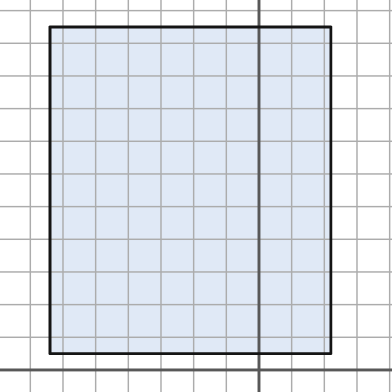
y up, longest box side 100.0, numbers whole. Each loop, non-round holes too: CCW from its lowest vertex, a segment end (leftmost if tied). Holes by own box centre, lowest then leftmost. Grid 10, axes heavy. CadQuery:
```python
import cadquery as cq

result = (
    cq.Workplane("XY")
    .moveTo(-64.0, 5.0)
    .lineTo(22.0, 5.0)
    .lineTo(22.0, 105.0)
    .lineTo(-64.0, 105.0)
    .close()
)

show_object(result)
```